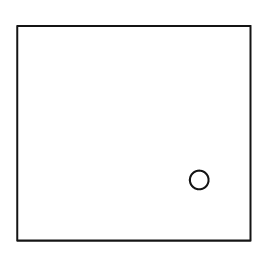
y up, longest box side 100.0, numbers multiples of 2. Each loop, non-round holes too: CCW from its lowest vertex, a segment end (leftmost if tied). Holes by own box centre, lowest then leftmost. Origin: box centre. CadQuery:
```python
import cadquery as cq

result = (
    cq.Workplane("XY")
    .moveTo(-50.0, -46.0)
    .lineTo(50.0, -46.0)
    .lineTo(50.0, 46.0)
    .lineTo(-50.0, 46.0)
    .close()
    .moveTo(28.0, -20.0)
    .circle(4.0)
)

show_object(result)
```